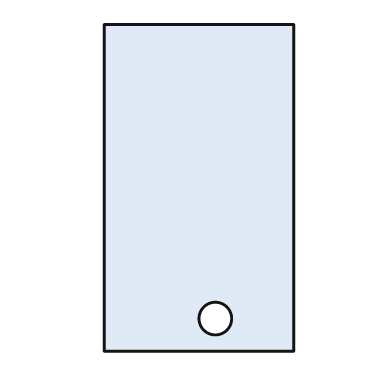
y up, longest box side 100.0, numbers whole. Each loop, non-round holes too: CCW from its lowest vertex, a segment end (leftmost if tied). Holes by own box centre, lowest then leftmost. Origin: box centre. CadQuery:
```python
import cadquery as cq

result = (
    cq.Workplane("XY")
    .moveTo(-29.0, -50.0)
    .lineTo(29.0, -50.0)
    .lineTo(29.0, 50.0)
    .lineTo(-29.0, 50.0)
    .close()
    .moveTo(5.0, -40.0)
    .circle(5.0)
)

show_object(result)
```